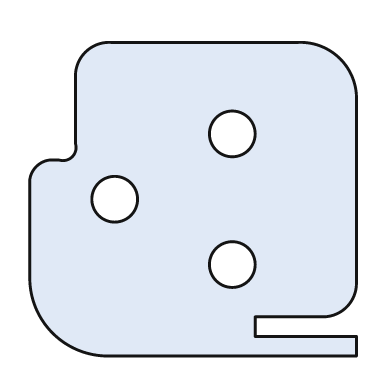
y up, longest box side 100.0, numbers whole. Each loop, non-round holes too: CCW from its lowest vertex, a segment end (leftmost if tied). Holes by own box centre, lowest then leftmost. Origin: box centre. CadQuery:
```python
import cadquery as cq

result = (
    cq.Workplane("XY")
    .moveTo(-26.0, -48.0)
    .lineTo(50.0, -48.0)
    .lineTo(50.0, -42.0)
    .lineTo(19.0, -42.0)
    .lineTo(19.0, -36.0)
    .lineTo(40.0, -36.0)
    .threePointArc((47.0, -33.0), (50.0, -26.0))
    .lineTo(50.0, 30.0)
    .threePointArc((45.0, 43.0), (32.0, 48.0))
    .lineTo(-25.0, 48.0)
    .threePointArc((-33.0, 45.0), (-36.0, 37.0))
    .lineTo(-36.0, 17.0)
    .threePointArc((-37.0, 13.0), (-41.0, 12.0))
    .lineTo(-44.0, 12.0)
    .threePointArc((-48.0, 10.0), (-50.0, 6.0))
    .lineTo(-50.0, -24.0)
    .threePointArc((-43.0, -41.0), (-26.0, -48.0))
    .close()
    .moveTo(12.0, -20.0)
    .circle(7.0)
    .moveTo(-24.0, 0.0)
    .circle(7.0)
    .moveTo(12.0, 20.0)
    .circle(7.0)
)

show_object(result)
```